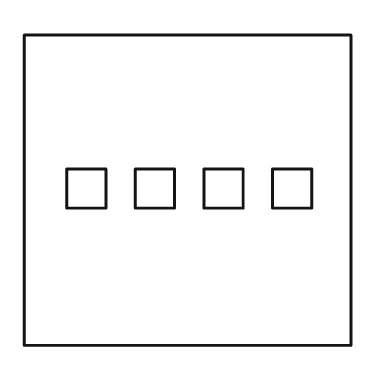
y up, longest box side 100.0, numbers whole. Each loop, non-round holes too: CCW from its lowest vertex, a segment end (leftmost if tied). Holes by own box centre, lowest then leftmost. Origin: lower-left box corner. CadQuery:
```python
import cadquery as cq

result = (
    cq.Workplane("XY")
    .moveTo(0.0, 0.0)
    .lineTo(100.0, 0.0)
    .lineTo(100.0, 95.0)
    .lineTo(0.0, 95.0)
    .close()
    .moveTo(13.0, 42.0)
    .lineTo(25.0, 42.0)
    .lineTo(25.0, 54.0)
    .lineTo(13.0, 54.0)
    .close()
    .moveTo(34.0, 42.0)
    .lineTo(46.0, 42.0)
    .lineTo(46.0, 54.0)
    .lineTo(34.0, 54.0)
    .close()
    .moveTo(55.0, 42.0)
    .lineTo(67.0, 42.0)
    .lineTo(67.0, 54.0)
    .lineTo(55.0, 54.0)
    .close()
    .moveTo(76.0, 42.0)
    .lineTo(88.0, 42.0)
    .lineTo(88.0, 54.0)
    .lineTo(76.0, 54.0)
    .close()
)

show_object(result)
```